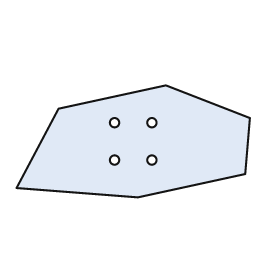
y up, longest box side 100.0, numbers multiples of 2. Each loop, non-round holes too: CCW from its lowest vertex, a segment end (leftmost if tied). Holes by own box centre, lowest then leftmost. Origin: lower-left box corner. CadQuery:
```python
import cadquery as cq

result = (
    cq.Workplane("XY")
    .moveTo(52.0, 0.0)
    .lineTo(98.0, 10.0)
    .lineTo(100.0, 34.0)
    .lineTo(64.0, 48.0)
    .lineTo(18.0, 38.0)
    .lineTo(0.0, 4.0)
    .close()
    .moveTo(42.0, 16.0)
    .circle(2.0)
    .moveTo(58.0, 16.0)
    .circle(2.0)
    .moveTo(42.0, 32.0)
    .circle(2.0)
    .moveTo(58.0, 32.0)
    .circle(2.0)
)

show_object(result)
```